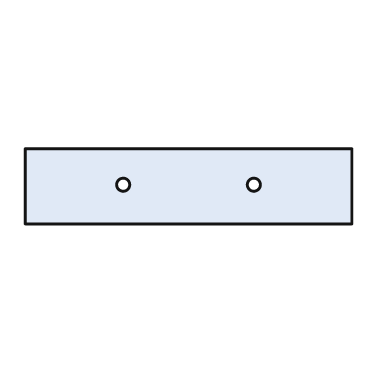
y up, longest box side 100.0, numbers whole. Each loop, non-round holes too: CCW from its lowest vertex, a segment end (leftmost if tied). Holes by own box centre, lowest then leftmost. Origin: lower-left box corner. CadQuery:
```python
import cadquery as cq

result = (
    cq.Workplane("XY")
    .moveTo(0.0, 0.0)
    .lineTo(100.0, 0.0)
    .lineTo(100.0, 23.0)
    .lineTo(0.0, 23.0)
    .close()
    .moveTo(30.0, 12.0)
    .circle(2.0)
    .moveTo(70.0, 12.0)
    .circle(2.0)
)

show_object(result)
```